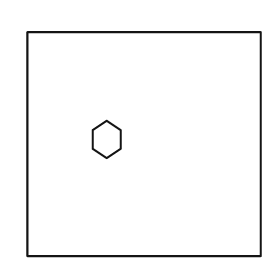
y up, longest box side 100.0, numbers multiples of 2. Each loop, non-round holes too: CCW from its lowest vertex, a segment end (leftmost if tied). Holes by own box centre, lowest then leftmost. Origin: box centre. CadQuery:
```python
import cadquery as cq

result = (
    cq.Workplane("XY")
    .moveTo(-50.0, -48.0)
    .lineTo(50.0, -48.0)
    .lineTo(50.0, 48.0)
    .lineTo(-50.0, 48.0)
    .close()
    .moveTo(-16.0, -6.0)
    .lineTo(-10.0, -2.0)
    .lineTo(-10.0, 6.0)
    .lineTo(-16.0, 10.0)
    .lineTo(-22.0, 6.0)
    .lineTo(-22.0, -2.0)
    .close()
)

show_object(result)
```